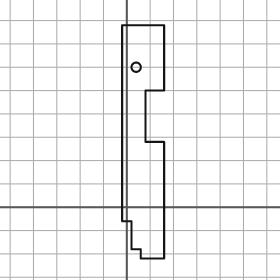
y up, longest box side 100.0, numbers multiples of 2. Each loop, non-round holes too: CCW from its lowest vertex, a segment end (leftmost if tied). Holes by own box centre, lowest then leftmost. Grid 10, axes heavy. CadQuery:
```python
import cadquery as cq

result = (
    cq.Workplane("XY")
    .moveTo(6.0, -22.0)
    .lineTo(16.0, -22.0)
    .lineTo(16.0, 28.0)
    .lineTo(8.0, 28.0)
    .lineTo(8.0, 50.0)
    .lineTo(16.0, 50.0)
    .lineTo(16.0, 78.0)
    .lineTo(-2.0, 78.0)
    .lineTo(-2.0, -6.0)
    .lineTo(2.0, -6.0)
    .lineTo(2.0, -18.0)
    .lineTo(6.0, -18.0)
    .close()
    .moveTo(4.0, 60.0)
    .circle(2.0)
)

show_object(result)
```